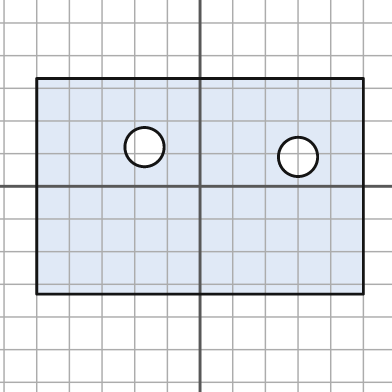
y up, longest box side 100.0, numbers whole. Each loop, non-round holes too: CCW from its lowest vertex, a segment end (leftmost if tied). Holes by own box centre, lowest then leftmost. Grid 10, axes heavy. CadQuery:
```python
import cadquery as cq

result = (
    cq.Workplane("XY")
    .moveTo(-50.0, -33.0)
    .lineTo(50.0, -33.0)
    .lineTo(50.0, 33.0)
    .lineTo(-50.0, 33.0)
    .close()
    .moveTo(30.0, 9.0)
    .circle(6.0)
    .moveTo(-17.0, 12.0)
    .circle(6.0)
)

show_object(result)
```